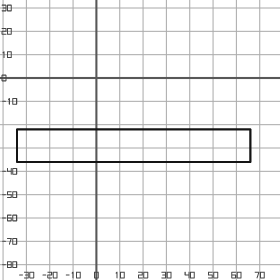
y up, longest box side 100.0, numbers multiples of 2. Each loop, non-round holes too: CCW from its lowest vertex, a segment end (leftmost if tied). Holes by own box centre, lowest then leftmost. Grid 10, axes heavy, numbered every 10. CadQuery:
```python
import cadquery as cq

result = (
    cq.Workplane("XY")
    .moveTo(-34.0, -36.0)
    .lineTo(66.0, -36.0)
    .lineTo(66.0, -22.0)
    .lineTo(-34.0, -22.0)
    .close()
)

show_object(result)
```